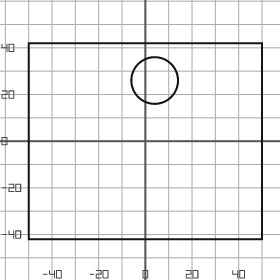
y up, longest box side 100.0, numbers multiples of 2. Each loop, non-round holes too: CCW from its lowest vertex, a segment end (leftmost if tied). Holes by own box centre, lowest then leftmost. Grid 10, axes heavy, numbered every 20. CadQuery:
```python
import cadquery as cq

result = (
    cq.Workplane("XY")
    .moveTo(-50.0, -42.0)
    .lineTo(50.0, -42.0)
    .lineTo(50.0, 42.0)
    .lineTo(-50.0, 42.0)
    .close()
    .moveTo(4.0, 26.0)
    .circle(10.0)
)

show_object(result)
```